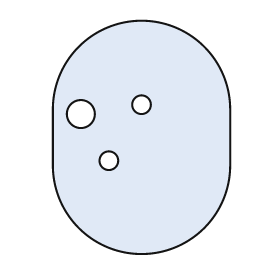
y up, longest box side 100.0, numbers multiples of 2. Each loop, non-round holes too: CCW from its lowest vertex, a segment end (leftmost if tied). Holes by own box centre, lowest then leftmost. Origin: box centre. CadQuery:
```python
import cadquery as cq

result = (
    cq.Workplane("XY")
    .moveTo(-38.0, -12.0)
    .threePointArc((0.0, -50.0), (38.0, -12.0))
    .lineTo(38.0, 12.0)
    .threePointArc((0.0, 50.0), (-38.0, 12.0))
    .close()
    .moveTo(-14.0, -10.0)
    .circle(4.0)
    .moveTo(-26.0, 10.0)
    .circle(6.0)
    .moveTo(0.0, 14.0)
    .circle(4.0)
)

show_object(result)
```